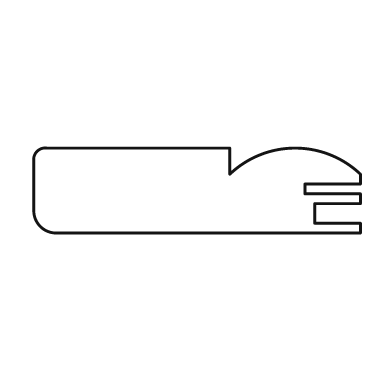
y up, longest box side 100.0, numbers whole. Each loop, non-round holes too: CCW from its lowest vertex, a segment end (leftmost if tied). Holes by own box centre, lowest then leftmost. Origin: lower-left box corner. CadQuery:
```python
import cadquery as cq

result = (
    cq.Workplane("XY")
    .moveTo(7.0, 0.0)
    .lineTo(100.0, 0.0)
    .lineTo(100.0, 3.0)
    .lineTo(86.0, 3.0)
    .lineTo(86.0, 9.0)
    .lineTo(100.0, 9.0)
    .lineTo(100.0, 12.0)
    .lineTo(83.0, 12.0)
    .lineTo(83.0, 15.0)
    .lineTo(100.0, 15.0)
    .lineTo(100.0, 18.0)
    .threePointArc((80.0, 26.0), (60.0, 18.0))
    .lineTo(60.0, 26.0)
    .lineTo(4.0, 26.0)
    .threePointArc((1.0, 25.0), (0.0, 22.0))
    .lineTo(0.0, 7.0)
    .threePointArc((2.0, 2.0), (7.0, 0.0))
    .close()
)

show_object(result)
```